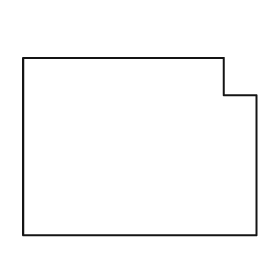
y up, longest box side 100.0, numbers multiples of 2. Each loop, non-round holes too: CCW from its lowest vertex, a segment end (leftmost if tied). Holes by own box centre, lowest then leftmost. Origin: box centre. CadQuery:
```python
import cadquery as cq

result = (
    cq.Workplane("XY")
    .moveTo(-50.0, -38.0)
    .lineTo(50.0, -38.0)
    .lineTo(50.0, 22.0)
    .lineTo(36.0, 22.0)
    .lineTo(36.0, 38.0)
    .lineTo(-50.0, 38.0)
    .close()
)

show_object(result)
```